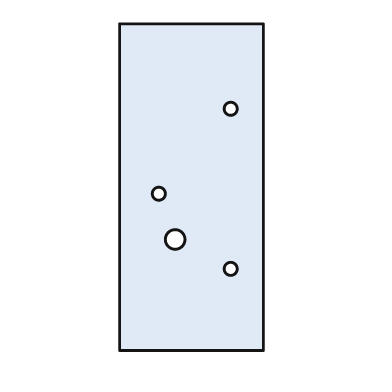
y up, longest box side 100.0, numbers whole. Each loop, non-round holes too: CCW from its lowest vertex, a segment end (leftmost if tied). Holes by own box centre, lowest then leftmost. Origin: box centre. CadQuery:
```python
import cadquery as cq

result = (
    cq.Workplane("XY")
    .moveTo(-22.0, -50.0)
    .lineTo(22.0, -50.0)
    .lineTo(22.0, 50.0)
    .lineTo(-22.0, 50.0)
    .close()
    .moveTo(12.0, -25.0)
    .circle(2.0)
    .moveTo(-5.0, -16.0)
    .circle(3.0)
    .moveTo(-10.0, -2.0)
    .circle(2.0)
    .moveTo(12.0, 24.0)
    .circle(2.0)
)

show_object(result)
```